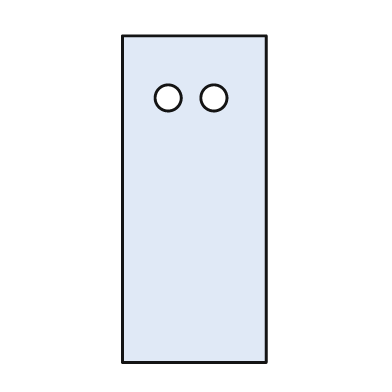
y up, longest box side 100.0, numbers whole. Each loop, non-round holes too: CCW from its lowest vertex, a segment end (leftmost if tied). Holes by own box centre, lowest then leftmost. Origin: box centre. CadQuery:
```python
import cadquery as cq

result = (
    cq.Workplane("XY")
    .moveTo(-22.0, -50.0)
    .lineTo(22.0, -50.0)
    .lineTo(22.0, 50.0)
    .lineTo(-22.0, 50.0)
    .close()
    .moveTo(-8.0, 31.0)
    .circle(4.0)
    .moveTo(6.0, 31.0)
    .circle(4.0)
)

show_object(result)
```